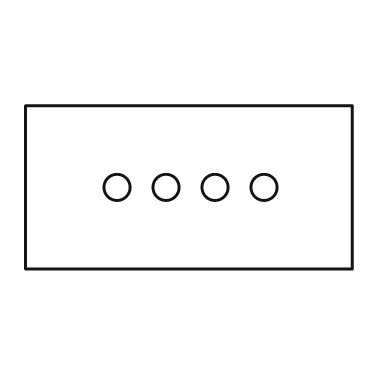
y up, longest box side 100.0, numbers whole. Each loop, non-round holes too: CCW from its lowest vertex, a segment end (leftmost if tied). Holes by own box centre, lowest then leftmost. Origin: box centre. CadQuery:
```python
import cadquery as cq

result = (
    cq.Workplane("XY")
    .moveTo(-50.0, -25.0)
    .lineTo(50.0, -25.0)
    .lineTo(50.0, 25.0)
    .lineTo(-50.0, 25.0)
    .close()
    .moveTo(-22.0, 0.0)
    .circle(4.0)
    .moveTo(-7.0, 0.0)
    .circle(4.0)
    .moveTo(8.0, 0.0)
    .circle(4.0)
    .moveTo(23.0, 0.0)
    .circle(4.0)
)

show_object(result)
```